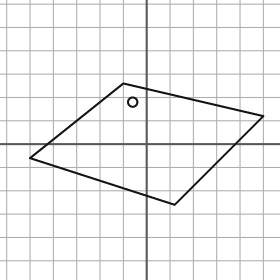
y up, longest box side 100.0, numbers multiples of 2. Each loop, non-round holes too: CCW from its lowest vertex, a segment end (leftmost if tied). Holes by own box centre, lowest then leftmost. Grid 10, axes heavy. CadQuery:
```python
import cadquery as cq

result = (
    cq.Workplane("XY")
    .moveTo(12.0, -26.0)
    .lineTo(50.0, 12.0)
    .lineTo(-10.0, 26.0)
    .lineTo(-50.0, -6.0)
    .close()
    .moveTo(-6.0, 18.0)
    .circle(2.0)
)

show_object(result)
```